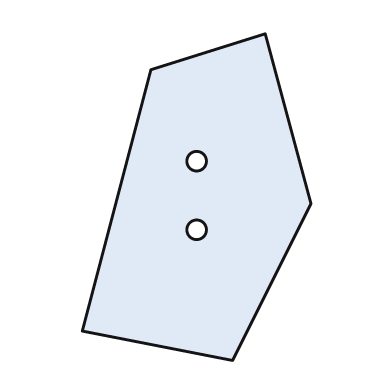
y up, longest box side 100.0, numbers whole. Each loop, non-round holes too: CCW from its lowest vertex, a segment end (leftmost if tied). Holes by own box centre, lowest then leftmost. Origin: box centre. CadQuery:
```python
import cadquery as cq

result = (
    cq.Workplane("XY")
    .moveTo(11.0, -50.0)
    .lineTo(35.0, -2.0)
    .lineTo(21.0, 50.0)
    .lineTo(-14.0, 39.0)
    .lineTo(-35.0, -41.0)
    .close()
    .moveTo(0.0, -10.0)
    .circle(3.0)
    .moveTo(0.0, 11.0)
    .circle(3.0)
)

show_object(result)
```